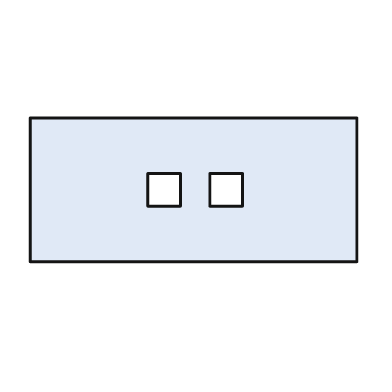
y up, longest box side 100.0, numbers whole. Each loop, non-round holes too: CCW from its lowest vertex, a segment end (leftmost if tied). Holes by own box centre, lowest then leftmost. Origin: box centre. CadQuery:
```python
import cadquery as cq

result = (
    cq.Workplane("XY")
    .moveTo(-50.0, -22.0)
    .lineTo(50.0, -22.0)
    .lineTo(50.0, 22.0)
    .lineTo(-50.0, 22.0)
    .close()
    .moveTo(-14.0, -5.0)
    .lineTo(-4.0, -5.0)
    .lineTo(-4.0, 5.0)
    .lineTo(-14.0, 5.0)
    .close()
    .moveTo(5.0, -5.0)
    .lineTo(15.0, -5.0)
    .lineTo(15.0, 5.0)
    .lineTo(5.0, 5.0)
    .close()
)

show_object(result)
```